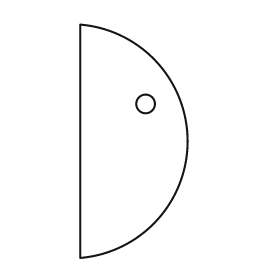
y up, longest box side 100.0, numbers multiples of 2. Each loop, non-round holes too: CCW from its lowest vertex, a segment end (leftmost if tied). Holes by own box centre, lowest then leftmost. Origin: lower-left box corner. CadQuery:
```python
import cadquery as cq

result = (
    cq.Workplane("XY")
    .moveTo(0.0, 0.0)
    .threePointArc((46.0, 50.0), (0.0, 100.0))
    .close()
    .moveTo(28.0, 66.0)
    .circle(4.0)
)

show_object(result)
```